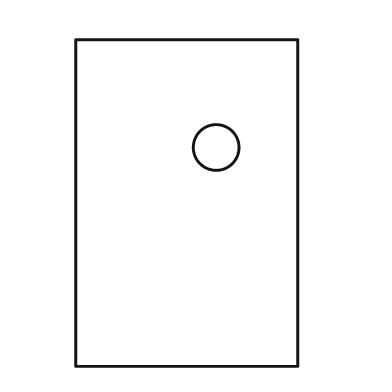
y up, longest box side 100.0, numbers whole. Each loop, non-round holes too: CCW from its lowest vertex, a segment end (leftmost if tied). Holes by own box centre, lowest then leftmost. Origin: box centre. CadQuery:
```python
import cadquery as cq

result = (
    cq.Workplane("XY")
    .moveTo(-34.0, -50.0)
    .lineTo(34.0, -50.0)
    .lineTo(34.0, 50.0)
    .lineTo(-34.0, 50.0)
    .close()
    .moveTo(9.0, 17.0)
    .circle(7.0)
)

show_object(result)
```